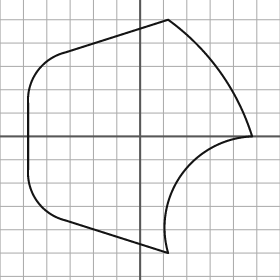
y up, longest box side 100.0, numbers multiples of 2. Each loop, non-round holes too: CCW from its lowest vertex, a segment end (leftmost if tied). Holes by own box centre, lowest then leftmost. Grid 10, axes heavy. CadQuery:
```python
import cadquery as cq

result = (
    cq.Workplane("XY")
    .moveTo(12.0, -50.0)
    .threePointArc((18.0, -16.0), (48.0, 0.0))
    .threePointArc((34.0, 28.0), (12.0, 50.0))
    .lineTo(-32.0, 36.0)
    .threePointArc((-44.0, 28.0), (-48.0, 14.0))
    .lineTo(-48.0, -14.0)
    .threePointArc((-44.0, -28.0), (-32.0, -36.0))
    .close()
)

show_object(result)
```